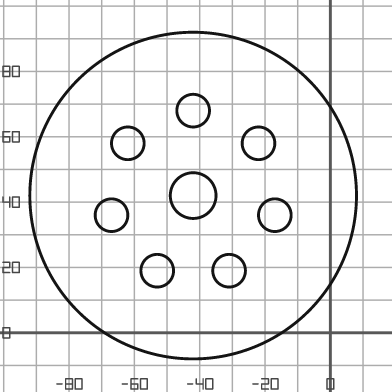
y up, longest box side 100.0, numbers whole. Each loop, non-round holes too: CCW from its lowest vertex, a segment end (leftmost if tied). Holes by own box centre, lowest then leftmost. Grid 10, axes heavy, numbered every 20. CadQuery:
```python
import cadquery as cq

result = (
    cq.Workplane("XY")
    .moveTo(-42.0, 42.0)
    .circle(50.0)
    .moveTo(-53.0, 19.0)
    .circle(5.0)
    .moveTo(-31.0, 19.0)
    .circle(5.0)
    .moveTo(-67.0, 36.0)
    .circle(5.0)
    .moveTo(-17.0, 36.0)
    .circle(5.0)
    .moveTo(-42.0, 42.0)
    .circle(7.0)
    .moveTo(-62.0, 58.0)
    .circle(5.0)
    .moveTo(-22.0, 58.0)
    .circle(5.0)
    .moveTo(-42.0, 68.0)
    .circle(5.0)
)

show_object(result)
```